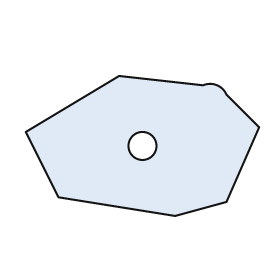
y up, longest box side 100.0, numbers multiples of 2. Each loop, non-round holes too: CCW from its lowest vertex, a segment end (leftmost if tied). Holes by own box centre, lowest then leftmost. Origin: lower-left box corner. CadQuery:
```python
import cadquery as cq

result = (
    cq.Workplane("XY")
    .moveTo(64.0, 0.0)
    .lineTo(86.0, 6.0)
    .lineTo(100.0, 38.0)
    .lineTo(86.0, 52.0)
    .threePointArc((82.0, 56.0), (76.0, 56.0))
    .lineTo(40.0, 60.0)
    .lineTo(0.0, 36.0)
    .lineTo(14.0, 8.0)
    .close()
    .moveTo(50.0, 30.0)
    .circle(6.0)
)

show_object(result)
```